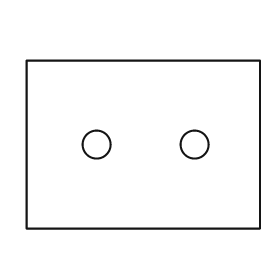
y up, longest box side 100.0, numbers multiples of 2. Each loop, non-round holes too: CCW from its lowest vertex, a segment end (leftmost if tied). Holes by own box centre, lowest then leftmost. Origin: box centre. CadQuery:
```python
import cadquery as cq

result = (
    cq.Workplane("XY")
    .moveTo(-50.0, -36.0)
    .lineTo(50.0, -36.0)
    .lineTo(50.0, 36.0)
    .lineTo(-50.0, 36.0)
    .close()
    .moveTo(-20.0, 0.0)
    .circle(6.0)
    .moveTo(22.0, 0.0)
    .circle(6.0)
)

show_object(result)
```